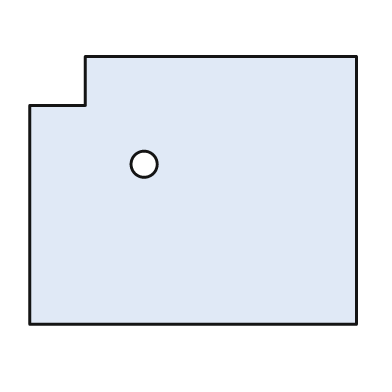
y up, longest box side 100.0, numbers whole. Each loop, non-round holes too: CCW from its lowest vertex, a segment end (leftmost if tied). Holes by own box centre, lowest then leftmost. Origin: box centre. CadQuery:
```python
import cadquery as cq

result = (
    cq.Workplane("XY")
    .moveTo(-50.0, -41.0)
    .lineTo(50.0, -41.0)
    .lineTo(50.0, 41.0)
    .lineTo(-33.0, 41.0)
    .lineTo(-33.0, 26.0)
    .lineTo(-50.0, 26.0)
    .close()
    .moveTo(-15.0, 8.0)
    .circle(4.0)
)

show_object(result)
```